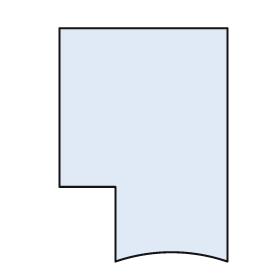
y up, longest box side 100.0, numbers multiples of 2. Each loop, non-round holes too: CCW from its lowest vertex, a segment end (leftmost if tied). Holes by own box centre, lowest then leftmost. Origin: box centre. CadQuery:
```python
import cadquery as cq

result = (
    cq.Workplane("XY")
    .moveTo(-12.0, -50.0)
    .threePointArc((12.0, -46.0), (36.0, -50.0))
    .lineTo(36.0, 50.0)
    .lineTo(-36.0, 50.0)
    .lineTo(-36.0, -18.0)
    .lineTo(-12.0, -18.0)
    .close()
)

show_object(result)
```